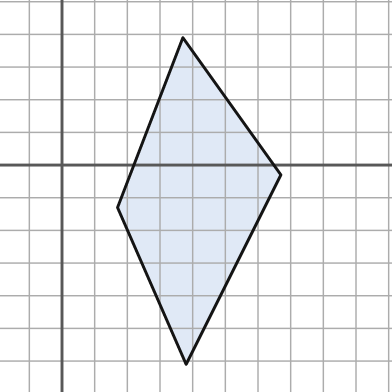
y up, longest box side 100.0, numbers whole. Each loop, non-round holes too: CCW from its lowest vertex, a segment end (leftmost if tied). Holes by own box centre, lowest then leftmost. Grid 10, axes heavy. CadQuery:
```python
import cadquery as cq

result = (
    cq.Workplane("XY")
    .moveTo(38.0, -61.0)
    .lineTo(67.0, -3.0)
    .lineTo(37.0, 39.0)
    .lineTo(17.0, -13.0)
    .close()
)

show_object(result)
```